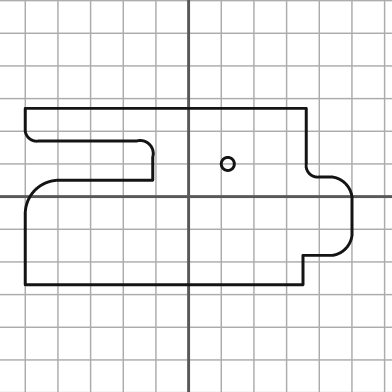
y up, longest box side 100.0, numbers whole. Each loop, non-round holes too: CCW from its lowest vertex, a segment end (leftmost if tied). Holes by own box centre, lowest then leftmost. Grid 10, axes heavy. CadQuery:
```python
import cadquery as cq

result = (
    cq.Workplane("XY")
    .moveTo(-50.0, -27.0)
    .lineTo(35.0, -27.0)
    .lineTo(35.0, -18.0)
    .lineTo(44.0, -18.0)
    .threePointArc((48.0, -16.0), (50.0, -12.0))
    .lineTo(50.0, 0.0)
    .threePointArc((48.0, 4.0), (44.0, 6.0))
    .lineTo(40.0, 6.0)
    .threePointArc((37.0, 7.0), (36.0, 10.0))
    .lineTo(36.0, 27.0)
    .lineTo(-50.0, 27.0)
    .lineTo(-50.0, 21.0)
    .threePointArc((-49.0, 18.0), (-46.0, 17.0))
    .lineTo(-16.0, 17.0)
    .threePointArc((-12.0, 16.0), (-11.0, 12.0))
    .lineTo(-11.0, 5.0)
    .lineTo(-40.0, 5.0)
    .threePointArc((-47.0, 2.0), (-50.0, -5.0))
    .close()
    .moveTo(12.0, 10.0)
    .circle(2.0)
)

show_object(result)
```